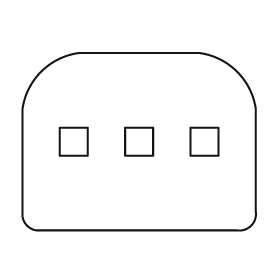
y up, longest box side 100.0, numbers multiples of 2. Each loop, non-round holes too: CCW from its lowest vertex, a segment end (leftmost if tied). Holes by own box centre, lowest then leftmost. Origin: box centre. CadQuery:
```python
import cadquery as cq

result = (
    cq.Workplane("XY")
    .moveTo(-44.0, -38.0)
    .lineTo(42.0, -38.0)
    .threePointArc((48.0, -36.0), (50.0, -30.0))
    .lineTo(50.0, 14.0)
    .threePointArc((42.0, 30.0), (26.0, 38.0))
    .lineTo(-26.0, 38.0)
    .threePointArc((-42.0, 30.0), (-50.0, 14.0))
    .lineTo(-50.0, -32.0)
    .threePointArc((-48.0, -36.0), (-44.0, -38.0))
    .close()
    .moveTo(-34.0, -6.0)
    .lineTo(-22.0, -6.0)
    .lineTo(-22.0, 6.0)
    .lineTo(-34.0, 6.0)
    .close()
    .moveTo(-6.0, -6.0)
    .lineTo(6.0, -6.0)
    .lineTo(6.0, 6.0)
    .lineTo(-6.0, 6.0)
    .close()
    .moveTo(22.0, -6.0)
    .lineTo(34.0, -6.0)
    .lineTo(34.0, 6.0)
    .lineTo(22.0, 6.0)
    .close()
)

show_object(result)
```